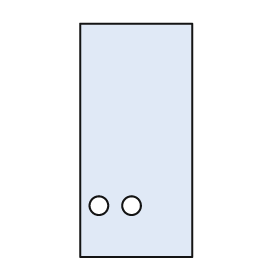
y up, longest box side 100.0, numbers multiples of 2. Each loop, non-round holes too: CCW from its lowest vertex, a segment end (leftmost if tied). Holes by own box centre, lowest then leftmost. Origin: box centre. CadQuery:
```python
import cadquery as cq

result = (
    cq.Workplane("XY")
    .moveTo(-24.0, -50.0)
    .lineTo(24.0, -50.0)
    .lineTo(24.0, 50.0)
    .lineTo(-24.0, 50.0)
    .close()
    .moveTo(-16.0, -28.0)
    .circle(4.0)
    .moveTo(-2.0, -28.0)
    .circle(4.0)
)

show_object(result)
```